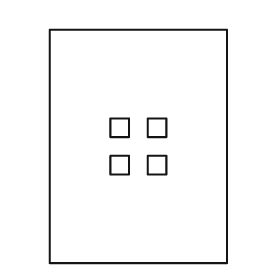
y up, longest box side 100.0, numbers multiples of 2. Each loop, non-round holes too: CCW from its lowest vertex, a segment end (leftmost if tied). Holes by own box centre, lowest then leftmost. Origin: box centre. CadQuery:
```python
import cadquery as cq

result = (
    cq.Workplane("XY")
    .moveTo(-38.0, -50.0)
    .lineTo(38.0, -50.0)
    .lineTo(38.0, 50.0)
    .lineTo(-38.0, 50.0)
    .close()
    .moveTo(-12.0, -12.0)
    .lineTo(-4.0, -12.0)
    .lineTo(-4.0, -4.0)
    .lineTo(-12.0, -4.0)
    .close()
    .moveTo(4.0, -12.0)
    .lineTo(12.0, -12.0)
    .lineTo(12.0, -4.0)
    .lineTo(4.0, -4.0)
    .close()
    .moveTo(-12.0, 4.0)
    .lineTo(-4.0, 4.0)
    .lineTo(-4.0, 12.0)
    .lineTo(-12.0, 12.0)
    .close()
    .moveTo(4.0, 4.0)
    .lineTo(12.0, 4.0)
    .lineTo(12.0, 12.0)
    .lineTo(4.0, 12.0)
    .close()
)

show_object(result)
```